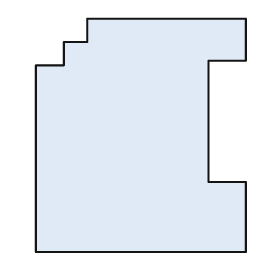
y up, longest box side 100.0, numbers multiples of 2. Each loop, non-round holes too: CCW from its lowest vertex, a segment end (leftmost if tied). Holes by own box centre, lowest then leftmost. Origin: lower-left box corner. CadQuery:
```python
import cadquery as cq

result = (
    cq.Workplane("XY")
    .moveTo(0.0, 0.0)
    .lineTo(90.0, 0.0)
    .lineTo(90.0, 30.0)
    .lineTo(74.0, 30.0)
    .lineTo(74.0, 82.0)
    .lineTo(90.0, 82.0)
    .lineTo(90.0, 100.0)
    .lineTo(22.0, 100.0)
    .lineTo(22.0, 90.0)
    .lineTo(12.0, 90.0)
    .lineTo(12.0, 80.0)
    .lineTo(0.0, 80.0)
    .close()
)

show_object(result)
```